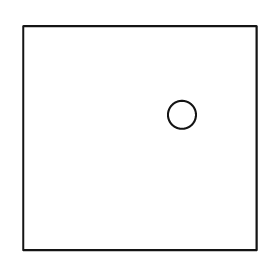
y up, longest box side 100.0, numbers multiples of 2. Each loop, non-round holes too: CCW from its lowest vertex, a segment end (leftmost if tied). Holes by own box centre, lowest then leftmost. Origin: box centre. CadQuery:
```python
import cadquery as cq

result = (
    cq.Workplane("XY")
    .moveTo(-50.0, -48.0)
    .lineTo(50.0, -48.0)
    .lineTo(50.0, 48.0)
    .lineTo(-50.0, 48.0)
    .close()
    .moveTo(18.0, 10.0)
    .circle(6.0)
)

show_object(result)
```